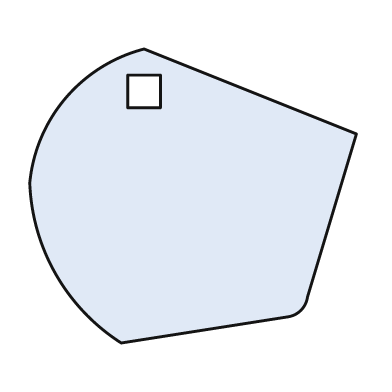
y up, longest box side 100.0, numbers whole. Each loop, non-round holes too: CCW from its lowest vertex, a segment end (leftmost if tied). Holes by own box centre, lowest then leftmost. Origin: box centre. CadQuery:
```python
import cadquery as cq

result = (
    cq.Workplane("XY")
    .moveTo(-22.0, -45.0)
    .lineTo(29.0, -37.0)
    .threePointArc((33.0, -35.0), (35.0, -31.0))
    .lineTo(50.0, 19.0)
    .lineTo(-15.0, 45.0)
    .threePointArc((-39.0, 30.0), (-50.0, 4.0))
    .threePointArc((-42.0, -24.0), (-22.0, -45.0))
    .close()
    .moveTo(-20.0, 27.0)
    .lineTo(-10.0, 27.0)
    .lineTo(-10.0, 37.0)
    .lineTo(-20.0, 37.0)
    .close()
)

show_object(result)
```